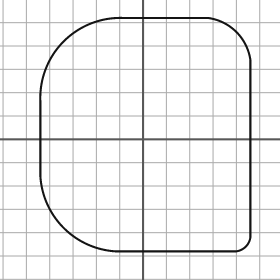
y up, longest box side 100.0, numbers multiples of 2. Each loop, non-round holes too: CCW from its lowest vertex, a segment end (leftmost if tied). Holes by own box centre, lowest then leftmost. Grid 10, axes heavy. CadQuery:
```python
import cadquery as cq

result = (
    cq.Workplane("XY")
    .moveTo(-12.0, -48.0)
    .lineTo(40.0, -48.0)
    .threePointArc((44.0, -46.0), (46.0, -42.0))
    .lineTo(46.0, 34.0)
    .threePointArc((40.0, 46.0), (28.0, 52.0))
    .lineTo(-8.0, 52.0)
    .threePointArc((-34.0, 42.0), (-44.0, 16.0))
    .lineTo(-44.0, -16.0)
    .threePointArc((-34.0, -38.0), (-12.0, -48.0))
    .close()
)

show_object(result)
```